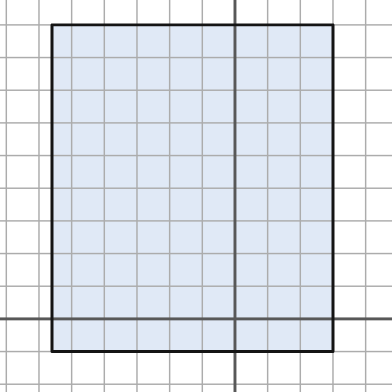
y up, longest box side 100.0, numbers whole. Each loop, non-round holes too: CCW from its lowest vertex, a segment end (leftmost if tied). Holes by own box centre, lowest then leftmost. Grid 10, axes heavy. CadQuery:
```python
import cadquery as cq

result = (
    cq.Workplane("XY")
    .moveTo(-56.0, -10.0)
    .lineTo(30.0, -10.0)
    .lineTo(30.0, 90.0)
    .lineTo(-56.0, 90.0)
    .close()
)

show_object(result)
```